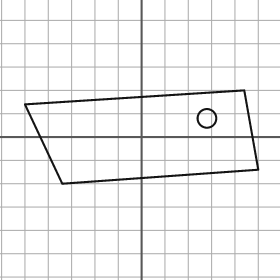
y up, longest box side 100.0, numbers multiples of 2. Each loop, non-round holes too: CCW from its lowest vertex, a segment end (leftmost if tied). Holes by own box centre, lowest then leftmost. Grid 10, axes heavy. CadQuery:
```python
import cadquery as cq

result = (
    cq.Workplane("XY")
    .moveTo(-34.0, -20.0)
    .lineTo(50.0, -14.0)
    .lineTo(44.0, 20.0)
    .lineTo(-50.0, 14.0)
    .close()
    .moveTo(28.0, 8.0)
    .circle(4.0)
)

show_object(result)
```